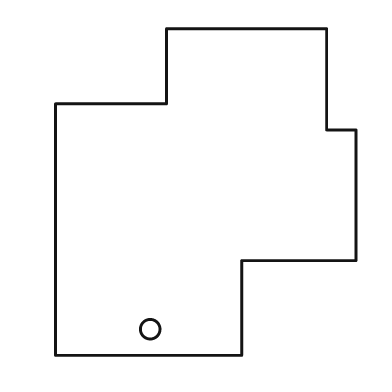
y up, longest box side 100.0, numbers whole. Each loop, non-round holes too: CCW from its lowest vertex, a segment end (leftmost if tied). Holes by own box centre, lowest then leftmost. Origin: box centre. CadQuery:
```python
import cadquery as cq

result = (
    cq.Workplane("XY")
    .moveTo(-46.0, -50.0)
    .lineTo(11.0, -50.0)
    .lineTo(11.0, -21.0)
    .lineTo(46.0, -21.0)
    .lineTo(46.0, 19.0)
    .lineTo(37.0, 19.0)
    .lineTo(37.0, 50.0)
    .lineTo(-12.0, 50.0)
    .lineTo(-12.0, 27.0)
    .lineTo(-46.0, 27.0)
    .close()
    .moveTo(-17.0, -42.0)
    .circle(3.0)
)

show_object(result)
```